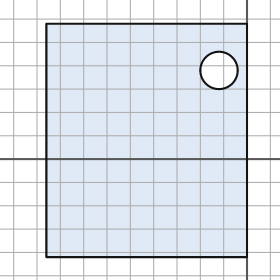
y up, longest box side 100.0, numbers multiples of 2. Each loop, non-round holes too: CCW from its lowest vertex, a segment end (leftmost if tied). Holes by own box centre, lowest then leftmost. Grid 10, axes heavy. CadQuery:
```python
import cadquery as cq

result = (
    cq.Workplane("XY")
    .moveTo(-86.0, -42.0)
    .lineTo(0.0, -42.0)
    .lineTo(0.0, 58.0)
    .lineTo(-86.0, 58.0)
    .close()
    .moveTo(-12.0, 38.0)
    .circle(8.0)
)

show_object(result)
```